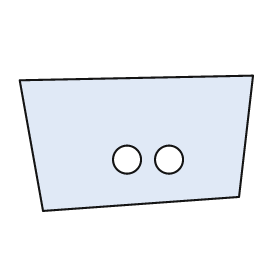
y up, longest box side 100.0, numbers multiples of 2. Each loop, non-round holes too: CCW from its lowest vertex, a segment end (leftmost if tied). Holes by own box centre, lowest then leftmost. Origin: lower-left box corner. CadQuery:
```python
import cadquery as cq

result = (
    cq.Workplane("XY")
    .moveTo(10.0, 0.0)
    .lineTo(94.0, 6.0)
    .lineTo(100.0, 58.0)
    .lineTo(0.0, 56.0)
    .close()
    .moveTo(46.0, 22.0)
    .circle(6.0)
    .moveTo(64.0, 22.0)
    .circle(6.0)
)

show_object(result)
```